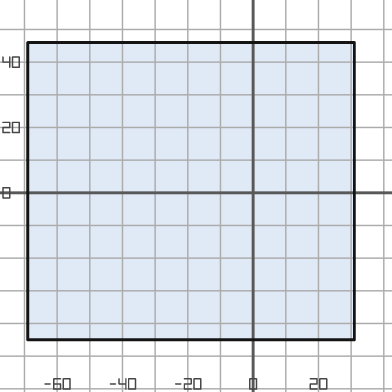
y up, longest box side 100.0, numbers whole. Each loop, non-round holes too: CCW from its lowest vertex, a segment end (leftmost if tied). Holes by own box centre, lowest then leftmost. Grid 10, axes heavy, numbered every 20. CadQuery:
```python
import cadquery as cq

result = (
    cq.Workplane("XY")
    .moveTo(-69.0, -45.0)
    .lineTo(31.0, -45.0)
    .lineTo(31.0, 46.0)
    .lineTo(-69.0, 46.0)
    .close()
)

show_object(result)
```